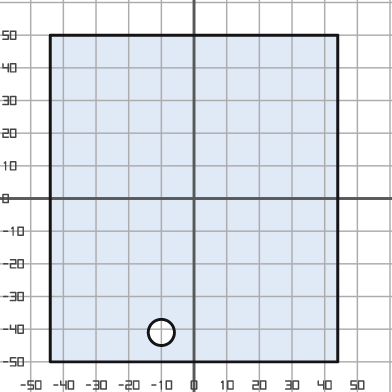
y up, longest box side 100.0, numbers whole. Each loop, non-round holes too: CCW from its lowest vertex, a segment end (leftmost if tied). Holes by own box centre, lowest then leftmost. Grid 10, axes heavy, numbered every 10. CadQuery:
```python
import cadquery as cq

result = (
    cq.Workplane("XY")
    .moveTo(-44.0, -50.0)
    .lineTo(44.0, -50.0)
    .lineTo(44.0, 50.0)
    .lineTo(-44.0, 50.0)
    .close()
    .moveTo(-10.0, -41.0)
    .circle(4.0)
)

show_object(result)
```